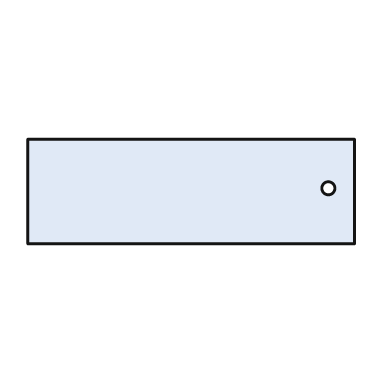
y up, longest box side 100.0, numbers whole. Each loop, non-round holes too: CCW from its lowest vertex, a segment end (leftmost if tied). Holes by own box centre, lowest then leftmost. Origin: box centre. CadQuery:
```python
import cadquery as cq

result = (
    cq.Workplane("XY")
    .moveTo(-50.0, -16.0)
    .lineTo(50.0, -16.0)
    .lineTo(50.0, 16.0)
    .lineTo(-50.0, 16.0)
    .close()
    .moveTo(42.0, 1.0)
    .circle(2.0)
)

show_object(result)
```